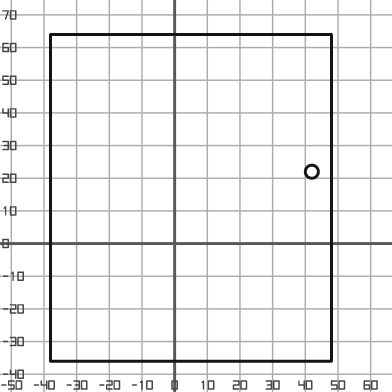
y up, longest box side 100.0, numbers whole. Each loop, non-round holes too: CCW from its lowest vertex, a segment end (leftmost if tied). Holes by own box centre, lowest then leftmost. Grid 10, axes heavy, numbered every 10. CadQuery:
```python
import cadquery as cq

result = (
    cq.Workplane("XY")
    .moveTo(-38.0, -36.0)
    .lineTo(48.0, -36.0)
    .lineTo(48.0, 64.0)
    .lineTo(-38.0, 64.0)
    .close()
    .moveTo(42.0, 22.0)
    .circle(2.0)
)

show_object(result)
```